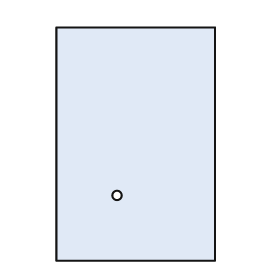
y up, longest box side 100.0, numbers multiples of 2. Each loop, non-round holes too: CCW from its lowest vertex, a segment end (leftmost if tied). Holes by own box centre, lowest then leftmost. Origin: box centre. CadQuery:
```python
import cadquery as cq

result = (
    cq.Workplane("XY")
    .moveTo(-34.0, -50.0)
    .lineTo(34.0, -50.0)
    .lineTo(34.0, 50.0)
    .lineTo(-34.0, 50.0)
    .close()
    .moveTo(-8.0, -22.0)
    .circle(2.0)
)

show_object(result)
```